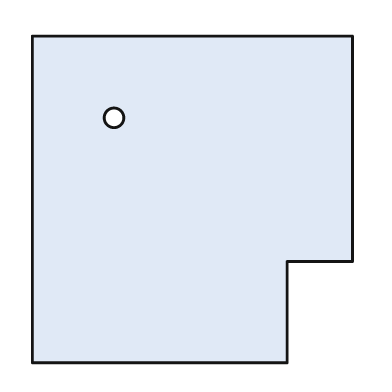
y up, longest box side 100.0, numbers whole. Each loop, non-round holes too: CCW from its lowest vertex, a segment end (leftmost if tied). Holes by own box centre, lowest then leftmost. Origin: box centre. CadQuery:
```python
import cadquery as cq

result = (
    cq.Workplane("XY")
    .moveTo(-49.0, -50.0)
    .lineTo(29.0, -50.0)
    .lineTo(29.0, -19.0)
    .lineTo(49.0, -19.0)
    .lineTo(49.0, 50.0)
    .lineTo(-49.0, 50.0)
    .close()
    .moveTo(-24.0, 25.0)
    .circle(3.0)
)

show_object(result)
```